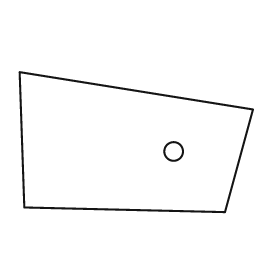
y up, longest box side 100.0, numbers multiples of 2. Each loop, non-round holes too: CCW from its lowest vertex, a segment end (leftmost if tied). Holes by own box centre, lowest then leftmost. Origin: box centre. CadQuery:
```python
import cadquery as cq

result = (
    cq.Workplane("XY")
    .moveTo(38.0, -30.0)
    .lineTo(50.0, 14.0)
    .lineTo(-50.0, 30.0)
    .lineTo(-48.0, -28.0)
    .close()
    .moveTo(16.0, -4.0)
    .circle(4.0)
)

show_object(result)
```